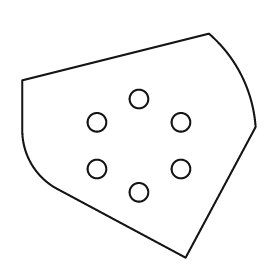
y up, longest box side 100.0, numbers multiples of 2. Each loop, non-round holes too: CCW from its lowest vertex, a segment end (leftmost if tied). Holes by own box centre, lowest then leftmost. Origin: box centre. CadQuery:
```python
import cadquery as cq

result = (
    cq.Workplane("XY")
    .moveTo(20.0, -48.0)
    .lineTo(50.0, 8.0)
    .threePointArc((44.0, 30.0), (30.0, 48.0))
    .lineTo(-50.0, 28.0)
    .lineTo(-50.0, 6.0)
    .threePointArc((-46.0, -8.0), (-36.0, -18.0))
    .close()
    .moveTo(0.0, -20.0)
    .circle(4.0)
    .moveTo(-18.0, -10.0)
    .circle(4.0)
    .moveTo(18.0, -10.0)
    .circle(4.0)
    .moveTo(-18.0, 10.0)
    .circle(4.0)
    .moveTo(18.0, 10.0)
    .circle(4.0)
    .moveTo(0.0, 20.0)
    .circle(4.0)
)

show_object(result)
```